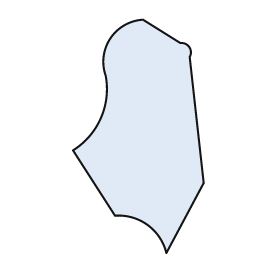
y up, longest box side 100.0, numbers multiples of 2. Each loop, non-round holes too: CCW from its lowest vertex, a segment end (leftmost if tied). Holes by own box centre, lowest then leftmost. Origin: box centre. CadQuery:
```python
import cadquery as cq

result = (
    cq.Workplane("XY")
    .moveTo(12.0, -50.0)
    .lineTo(28.0, -20.0)
    .lineTo(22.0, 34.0)
    .threePointArc((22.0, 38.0), (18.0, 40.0))
    .lineTo(2.0, 50.0)
    .threePointArc((-12.0, 42.0), (-14.0, 26.0))
    .threePointArc((-16.0, 8.0), (-28.0, -6.0))
    .lineTo(-10.0, -34.0)
    .threePointArc((4.0, -38.0), (12.0, -50.0))
    .close()
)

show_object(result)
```